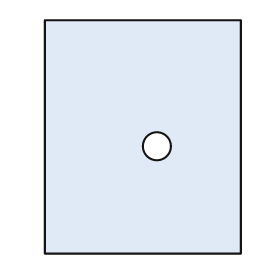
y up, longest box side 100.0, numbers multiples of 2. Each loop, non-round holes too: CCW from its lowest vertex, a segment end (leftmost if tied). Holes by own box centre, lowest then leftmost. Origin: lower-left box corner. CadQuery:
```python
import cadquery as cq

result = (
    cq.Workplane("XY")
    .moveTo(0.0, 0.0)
    .lineTo(84.0, 0.0)
    .lineTo(84.0, 100.0)
    .lineTo(0.0, 100.0)
    .close()
    .moveTo(48.0, 46.0)
    .circle(6.0)
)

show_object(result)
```